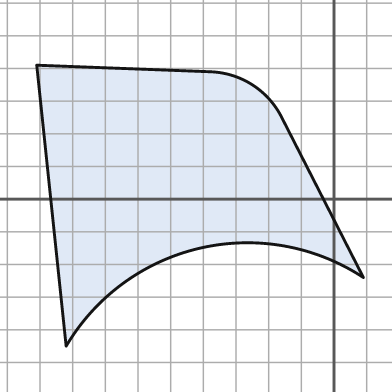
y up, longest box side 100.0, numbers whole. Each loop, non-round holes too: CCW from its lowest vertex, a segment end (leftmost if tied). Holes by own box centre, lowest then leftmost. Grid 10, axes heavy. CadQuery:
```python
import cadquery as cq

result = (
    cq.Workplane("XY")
    .moveTo(-82.0, -45.0)
    .threePointArc((-41.0, -15.0), (9.0, -24.0))
    .lineTo(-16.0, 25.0)
    .threePointArc((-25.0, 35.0), (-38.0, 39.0))
    .lineTo(-91.0, 41.0)
    .close()
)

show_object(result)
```